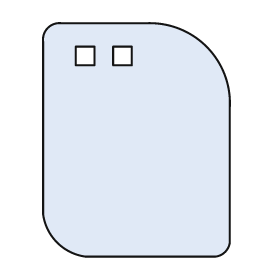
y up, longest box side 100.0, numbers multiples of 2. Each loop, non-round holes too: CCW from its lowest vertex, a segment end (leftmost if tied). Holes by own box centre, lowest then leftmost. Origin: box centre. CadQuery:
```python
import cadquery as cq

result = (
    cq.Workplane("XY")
    .moveTo(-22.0, -50.0)
    .lineTo(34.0, -50.0)
    .threePointArc((38.0, -48.0), (40.0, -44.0))
    .lineTo(40.0, 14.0)
    .threePointArc((30.0, 40.0), (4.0, 50.0))
    .lineTo(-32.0, 50.0)
    .threePointArc((-38.0, 48.0), (-40.0, 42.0))
    .lineTo(-40.0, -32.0)
    .threePointArc((-34.0, -44.0), (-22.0, -50.0))
    .close()
    .moveTo(-26.0, 32.0)
    .lineTo(-18.0, 32.0)
    .lineTo(-18.0, 40.0)
    .lineTo(-26.0, 40.0)
    .close()
    .moveTo(-10.0, 32.0)
    .lineTo(-2.0, 32.0)
    .lineTo(-2.0, 40.0)
    .lineTo(-10.0, 40.0)
    .close()
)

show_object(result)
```